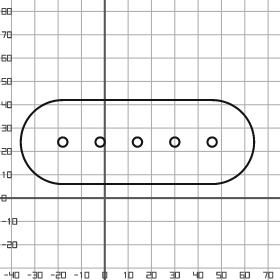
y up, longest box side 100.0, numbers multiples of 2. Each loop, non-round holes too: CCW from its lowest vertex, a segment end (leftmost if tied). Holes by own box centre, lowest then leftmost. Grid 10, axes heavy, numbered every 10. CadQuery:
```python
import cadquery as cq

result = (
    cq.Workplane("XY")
    .moveTo(-18.0, 6.0)
    .lineTo(46.0, 6.0)
    .threePointArc((64.0, 24.0), (46.0, 42.0))
    .lineTo(-18.0, 42.0)
    .threePointArc((-36.0, 24.0), (-18.0, 6.0))
    .close()
    .moveTo(-18.0, 24.0)
    .circle(2.0)
    .moveTo(-2.0, 24.0)
    .circle(2.0)
    .moveTo(14.0, 24.0)
    .circle(2.0)
    .moveTo(30.0, 24.0)
    .circle(2.0)
    .moveTo(46.0, 24.0)
    .circle(2.0)
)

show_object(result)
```